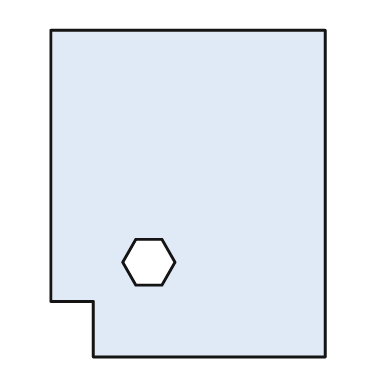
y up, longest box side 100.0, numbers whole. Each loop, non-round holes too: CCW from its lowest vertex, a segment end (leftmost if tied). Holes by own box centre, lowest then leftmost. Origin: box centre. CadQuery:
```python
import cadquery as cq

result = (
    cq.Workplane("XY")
    .moveTo(-29.0, -50.0)
    .lineTo(42.0, -50.0)
    .lineTo(42.0, 50.0)
    .lineTo(-42.0, 50.0)
    .lineTo(-42.0, -33.0)
    .lineTo(-29.0, -33.0)
    .close()
    .moveTo(-16.0, -28.0)
    .lineTo(-8.0, -28.0)
    .lineTo(-4.0, -21.0)
    .lineTo(-8.0, -14.0)
    .lineTo(-16.0, -14.0)
    .lineTo(-20.0, -21.0)
    .close()
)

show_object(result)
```